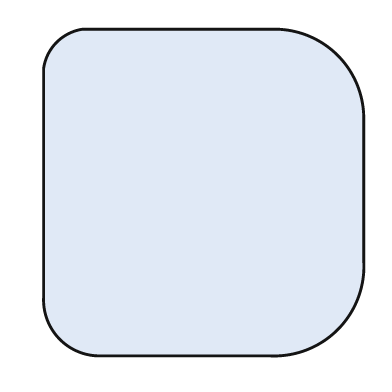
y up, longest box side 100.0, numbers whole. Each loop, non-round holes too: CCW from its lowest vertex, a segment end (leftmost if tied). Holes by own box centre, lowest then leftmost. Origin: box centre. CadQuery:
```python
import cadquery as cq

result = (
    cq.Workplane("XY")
    .moveTo(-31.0, -50.0)
    .lineTo(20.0, -50.0)
    .threePointArc((41.0, -42.0), (49.0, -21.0))
    .lineTo(49.0, 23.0)
    .threePointArc((41.0, 42.0), (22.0, 50.0))
    .lineTo(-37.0, 50.0)
    .threePointArc((-45.0, 46.0), (-49.0, 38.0))
    .lineTo(-49.0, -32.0)
    .threePointArc((-44.0, -45.0), (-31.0, -50.0))
    .close()
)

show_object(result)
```